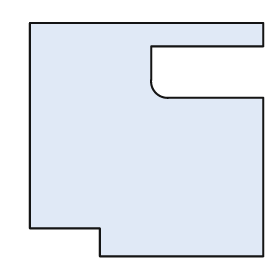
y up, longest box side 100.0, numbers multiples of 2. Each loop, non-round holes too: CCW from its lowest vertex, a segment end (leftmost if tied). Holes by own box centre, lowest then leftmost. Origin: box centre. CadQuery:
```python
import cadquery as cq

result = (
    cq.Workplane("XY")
    .moveTo(-20.0, -50.0)
    .lineTo(50.0, -50.0)
    .lineTo(50.0, 18.0)
    .lineTo(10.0, 18.0)
    .threePointArc((4.0, 20.0), (2.0, 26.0))
    .lineTo(2.0, 40.0)
    .lineTo(50.0, 40.0)
    .lineTo(50.0, 50.0)
    .lineTo(-50.0, 50.0)
    .lineTo(-50.0, -38.0)
    .lineTo(-20.0, -38.0)
    .close()
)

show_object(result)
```